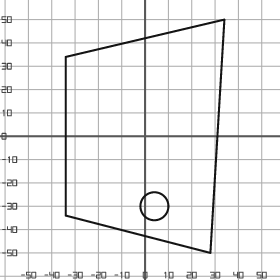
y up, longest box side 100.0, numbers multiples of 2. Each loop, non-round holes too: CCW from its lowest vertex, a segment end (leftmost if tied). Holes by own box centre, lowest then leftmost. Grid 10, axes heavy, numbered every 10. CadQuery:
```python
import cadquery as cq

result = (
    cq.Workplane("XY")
    .moveTo(28.0, -50.0)
    .lineTo(34.0, 50.0)
    .lineTo(-34.0, 34.0)
    .lineTo(-34.0, -34.0)
    .close()
    .moveTo(4.0, -30.0)
    .circle(6.0)
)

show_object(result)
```